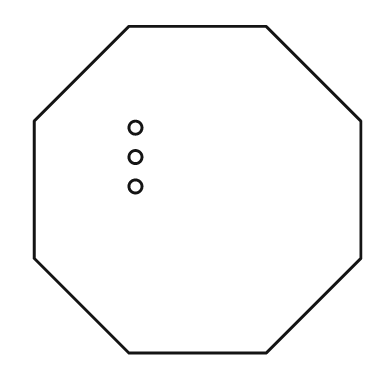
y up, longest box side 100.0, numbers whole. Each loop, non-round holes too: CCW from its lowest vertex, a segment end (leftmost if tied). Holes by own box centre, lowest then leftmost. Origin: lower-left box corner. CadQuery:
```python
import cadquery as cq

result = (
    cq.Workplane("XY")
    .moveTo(29.0, 0.0)
    .lineTo(71.0, 0.0)
    .lineTo(100.0, 29.0)
    .lineTo(100.0, 71.0)
    .lineTo(71.0, 100.0)
    .lineTo(29.0, 100.0)
    .lineTo(0.0, 71.0)
    .lineTo(0.0, 29.0)
    .close()
    .moveTo(31.0, 51.0)
    .circle(2.0)
    .moveTo(31.0, 60.0)
    .circle(2.0)
    .moveTo(31.0, 69.0)
    .circle(2.0)
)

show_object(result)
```